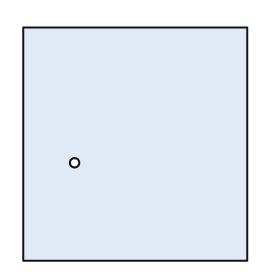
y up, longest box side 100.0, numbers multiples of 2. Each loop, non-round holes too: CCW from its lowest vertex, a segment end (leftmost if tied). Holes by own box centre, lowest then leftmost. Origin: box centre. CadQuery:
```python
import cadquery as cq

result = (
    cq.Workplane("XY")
    .moveTo(-48.0, -50.0)
    .lineTo(48.0, -50.0)
    .lineTo(48.0, 50.0)
    .lineTo(-48.0, 50.0)
    .close()
    .moveTo(-26.0, -8.0)
    .circle(2.0)
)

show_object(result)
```